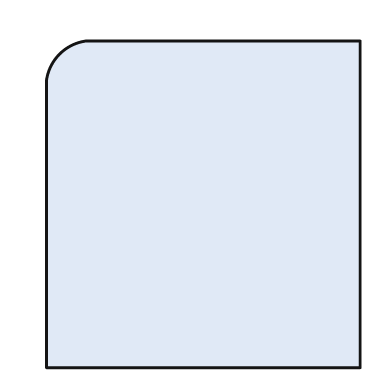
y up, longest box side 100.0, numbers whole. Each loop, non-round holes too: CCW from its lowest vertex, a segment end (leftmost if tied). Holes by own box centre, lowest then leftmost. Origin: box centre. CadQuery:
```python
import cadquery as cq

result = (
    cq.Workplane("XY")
    .moveTo(-48.0, -50.0)
    .lineTo(48.0, -50.0)
    .lineTo(48.0, 50.0)
    .lineTo(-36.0, 50.0)
    .threePointArc((-44.0, 46.0), (-48.0, 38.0))
    .close()
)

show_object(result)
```